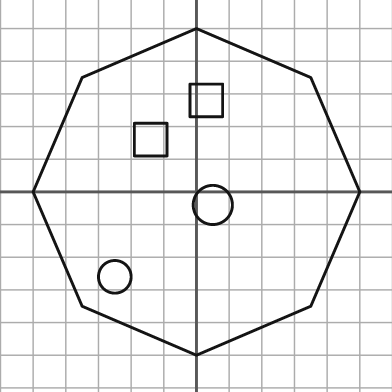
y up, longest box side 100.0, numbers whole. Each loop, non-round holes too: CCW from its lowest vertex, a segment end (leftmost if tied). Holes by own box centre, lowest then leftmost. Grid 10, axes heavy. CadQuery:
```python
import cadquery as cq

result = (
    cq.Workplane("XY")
    .moveTo(0.0, -50.0)
    .lineTo(35.0, -35.0)
    .lineTo(50.0, 0.0)
    .lineTo(35.0, 35.0)
    .lineTo(0.0, 50.0)
    .lineTo(-35.0, 35.0)
    .lineTo(-50.0, 0.0)
    .lineTo(-35.0, -35.0)
    .close()
    .moveTo(-25.0, -26.0)
    .circle(5.0)
    .moveTo(5.0, -4.0)
    .circle(6.0)
    .moveTo(-19.0, 11.0)
    .lineTo(-9.0, 11.0)
    .lineTo(-9.0, 21.0)
    .lineTo(-19.0, 21.0)
    .close()
    .moveTo(-2.0, 23.0)
    .lineTo(8.0, 23.0)
    .lineTo(8.0, 33.0)
    .lineTo(-2.0, 33.0)
    .close()
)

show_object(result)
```